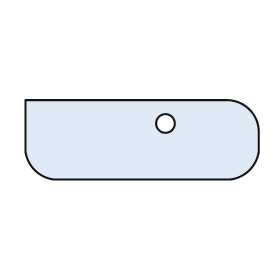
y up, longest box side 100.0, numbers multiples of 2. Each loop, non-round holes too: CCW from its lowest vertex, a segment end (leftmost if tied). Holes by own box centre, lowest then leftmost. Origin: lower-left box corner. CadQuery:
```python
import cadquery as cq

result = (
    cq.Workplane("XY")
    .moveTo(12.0, 0.0)
    .lineTo(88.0, 0.0)
    .threePointArc((96.0, 4.0), (100.0, 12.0))
    .lineTo(100.0, 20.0)
    .threePointArc((96.0, 30.0), (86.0, 34.0))
    .lineTo(0.0, 34.0)
    .lineTo(0.0, 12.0)
    .threePointArc((4.0, 4.0), (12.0, 0.0))
    .close()
    .moveTo(60.0, 24.0)
    .circle(4.0)
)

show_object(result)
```